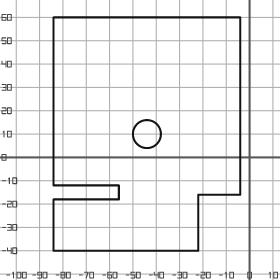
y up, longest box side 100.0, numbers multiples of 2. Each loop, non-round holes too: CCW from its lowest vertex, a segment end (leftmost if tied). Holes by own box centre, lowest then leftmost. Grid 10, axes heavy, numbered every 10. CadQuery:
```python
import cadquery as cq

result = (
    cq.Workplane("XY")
    .moveTo(-84.0, -40.0)
    .lineTo(-22.0, -40.0)
    .lineTo(-22.0, -16.0)
    .lineTo(-4.0, -16.0)
    .lineTo(-4.0, 60.0)
    .lineTo(-84.0, 60.0)
    .lineTo(-84.0, -12.0)
    .lineTo(-56.0, -12.0)
    .lineTo(-56.0, -18.0)
    .lineTo(-84.0, -18.0)
    .close()
    .moveTo(-44.0, 10.0)
    .circle(6.0)
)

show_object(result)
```